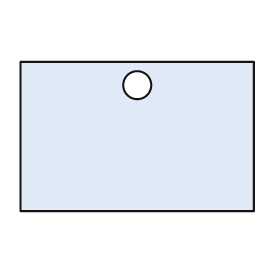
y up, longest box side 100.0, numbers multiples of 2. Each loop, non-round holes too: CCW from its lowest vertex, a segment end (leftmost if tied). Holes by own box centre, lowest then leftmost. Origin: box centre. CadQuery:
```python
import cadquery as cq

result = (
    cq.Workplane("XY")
    .moveTo(-50.0, -32.0)
    .lineTo(50.0, -32.0)
    .lineTo(50.0, 32.0)
    .lineTo(-50.0, 32.0)
    .close()
    .moveTo(0.0, 22.0)
    .circle(6.0)
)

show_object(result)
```